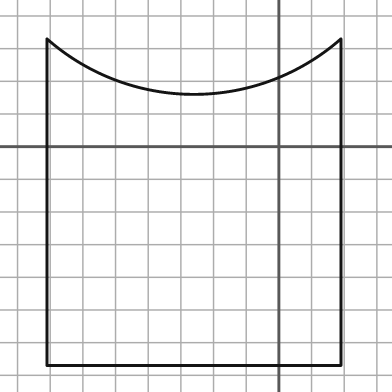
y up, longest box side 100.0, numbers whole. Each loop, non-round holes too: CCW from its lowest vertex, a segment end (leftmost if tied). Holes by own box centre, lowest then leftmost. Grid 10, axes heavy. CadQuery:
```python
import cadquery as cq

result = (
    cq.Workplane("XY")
    .moveTo(-71.0, -67.0)
    .lineTo(19.0, -67.0)
    .lineTo(19.0, 33.0)
    .threePointArc((-26.0, 16.0), (-71.0, 33.0))
    .close()
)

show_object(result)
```